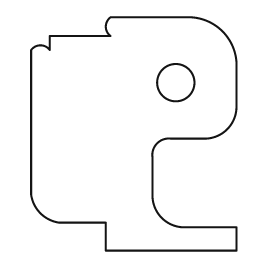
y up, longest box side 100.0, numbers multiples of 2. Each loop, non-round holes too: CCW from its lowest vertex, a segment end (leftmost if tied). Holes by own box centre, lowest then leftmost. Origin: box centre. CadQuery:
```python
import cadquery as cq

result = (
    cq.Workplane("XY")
    .moveTo(-12.0, -50.0)
    .lineTo(44.0, -50.0)
    .lineTo(44.0, -40.0)
    .lineTo(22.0, -40.0)
    .threePointArc((12.0, -36.0), (8.0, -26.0))
    .lineTo(8.0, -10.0)
    .threePointArc((10.0, -4.0), (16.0, -2.0))
    .lineTo(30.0, -2.0)
    .threePointArc((40.0, 2.0), (44.0, 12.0))
    .lineTo(44.0, 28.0)
    .threePointArc((38.0, 44.0), (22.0, 50.0))
    .lineTo(-10.0, 50.0)
    .threePointArc((-12.0, 46.0), (-10.0, 42.0))
    .lineTo(-36.0, 42.0)
    .lineTo(-36.0, 36.0)
    .threePointArc((-40.0, 38.0), (-44.0, 36.0))
    .lineTo(-44.0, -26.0)
    .threePointArc((-40.0, -34.0), (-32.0, -38.0))
    .lineTo(-12.0, -38.0)
    .close()
    .moveTo(18.0, 22.0)
    .circle(8.0)
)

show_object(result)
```